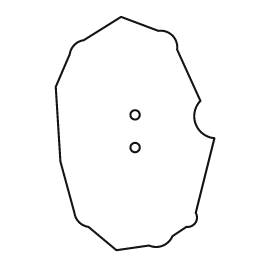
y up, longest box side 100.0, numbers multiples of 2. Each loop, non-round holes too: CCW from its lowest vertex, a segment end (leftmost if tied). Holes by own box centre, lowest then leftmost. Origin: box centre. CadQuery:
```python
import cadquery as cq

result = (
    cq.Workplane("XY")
    .moveTo(-8.0, -50.0)
    .lineTo(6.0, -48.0)
    .threePointArc((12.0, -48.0), (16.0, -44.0))
    .lineTo(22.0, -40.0)
    .threePointArc((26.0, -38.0), (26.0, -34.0))
    .lineTo(34.0, -2.0)
    .threePointArc((26.0, 4.0), (28.0, 14.0))
    .lineTo(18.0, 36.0)
    .threePointArc((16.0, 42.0), (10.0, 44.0))
    .lineTo(-6.0, 50.0)
    .lineTo(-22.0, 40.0)
    .threePointArc((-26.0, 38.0), (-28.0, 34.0))
    .lineTo(-34.0, 20.0)
    .lineTo(-32.0, -12.0)
    .lineTo(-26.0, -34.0)
    .threePointArc((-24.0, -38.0), (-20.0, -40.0))
    .close()
    .moveTo(0.0, -6.0)
    .circle(2.0)
    .moveTo(0.0, 8.0)
    .circle(2.0)
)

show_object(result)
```